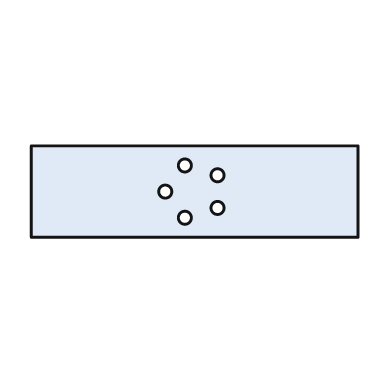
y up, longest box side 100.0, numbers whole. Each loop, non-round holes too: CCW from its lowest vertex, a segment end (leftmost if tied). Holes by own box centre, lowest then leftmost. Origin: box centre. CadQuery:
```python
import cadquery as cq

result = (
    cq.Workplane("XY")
    .moveTo(-50.0, -14.0)
    .lineTo(50.0, -14.0)
    .lineTo(50.0, 14.0)
    .lineTo(-50.0, 14.0)
    .close()
    .moveTo(-3.0, -8.0)
    .circle(2.0)
    .moveTo(7.0, -5.0)
    .circle(2.0)
    .moveTo(-9.0, 0.0)
    .circle(2.0)
    .moveTo(7.0, 5.0)
    .circle(2.0)
    .moveTo(-3.0, 8.0)
    .circle(2.0)
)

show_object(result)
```